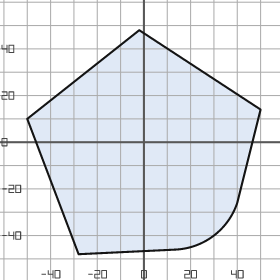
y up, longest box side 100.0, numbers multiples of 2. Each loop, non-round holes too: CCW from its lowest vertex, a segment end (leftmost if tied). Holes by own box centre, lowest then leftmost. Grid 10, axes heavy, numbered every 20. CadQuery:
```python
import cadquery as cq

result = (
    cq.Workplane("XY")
    .moveTo(-28.0, -48.0)
    .lineTo(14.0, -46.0)
    .threePointArc((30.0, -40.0), (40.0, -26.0))
    .lineTo(50.0, 14.0)
    .lineTo(-2.0, 48.0)
    .lineTo(-50.0, 10.0)
    .close()
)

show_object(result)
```